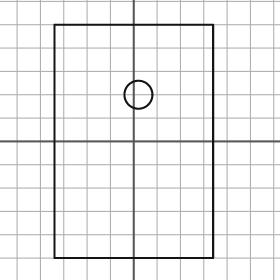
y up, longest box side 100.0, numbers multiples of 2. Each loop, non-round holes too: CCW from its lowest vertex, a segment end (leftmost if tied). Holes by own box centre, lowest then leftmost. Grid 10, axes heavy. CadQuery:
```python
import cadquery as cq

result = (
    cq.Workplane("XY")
    .moveTo(-34.0, -50.0)
    .lineTo(34.0, -50.0)
    .lineTo(34.0, 50.0)
    .lineTo(-34.0, 50.0)
    .close()
    .moveTo(2.0, 20.0)
    .circle(6.0)
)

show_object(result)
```